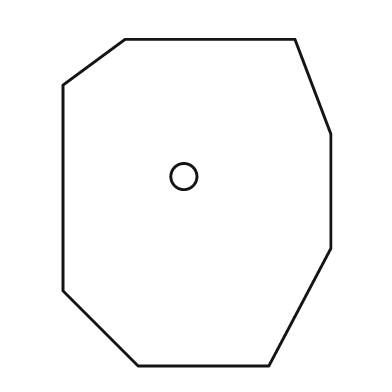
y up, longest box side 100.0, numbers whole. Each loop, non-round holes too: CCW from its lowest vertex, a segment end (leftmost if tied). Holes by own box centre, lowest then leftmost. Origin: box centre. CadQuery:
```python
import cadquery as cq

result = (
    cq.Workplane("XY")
    .moveTo(-18.0, -50.0)
    .lineTo(22.0, -50.0)
    .lineTo(41.0, -14.0)
    .lineTo(41.0, 21.0)
    .lineTo(30.0, 50.0)
    .lineTo(-22.0, 50.0)
    .lineTo(-41.0, 36.0)
    .lineTo(-41.0, -27.0)
    .close()
    .moveTo(-4.0, 8.0)
    .circle(4.0)
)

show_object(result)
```